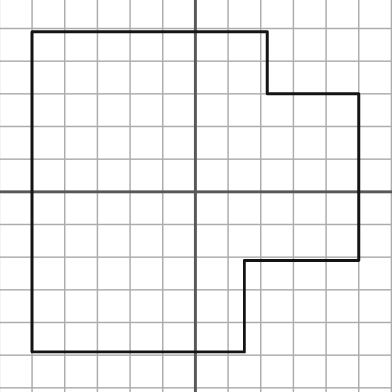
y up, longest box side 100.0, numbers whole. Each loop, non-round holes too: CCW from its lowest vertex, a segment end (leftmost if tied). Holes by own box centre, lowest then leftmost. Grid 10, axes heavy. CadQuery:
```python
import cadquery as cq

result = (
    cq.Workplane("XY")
    .moveTo(-50.0, -49.0)
    .lineTo(15.0, -49.0)
    .lineTo(15.0, -21.0)
    .lineTo(50.0, -21.0)
    .lineTo(50.0, 30.0)
    .lineTo(22.0, 30.0)
    .lineTo(22.0, 49.0)
    .lineTo(-50.0, 49.0)
    .close()
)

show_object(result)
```